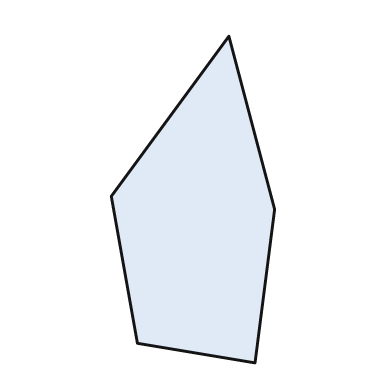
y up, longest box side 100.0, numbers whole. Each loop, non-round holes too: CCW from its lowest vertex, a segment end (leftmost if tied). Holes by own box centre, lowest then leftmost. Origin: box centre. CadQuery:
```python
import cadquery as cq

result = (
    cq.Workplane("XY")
    .moveTo(19.0, -50.0)
    .lineTo(25.0, -3.0)
    .lineTo(11.0, 50.0)
    .lineTo(-25.0, 1.0)
    .lineTo(-17.0, -44.0)
    .close()
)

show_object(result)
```